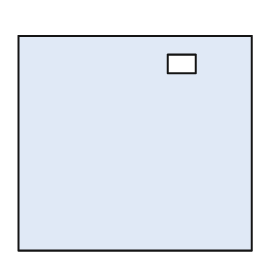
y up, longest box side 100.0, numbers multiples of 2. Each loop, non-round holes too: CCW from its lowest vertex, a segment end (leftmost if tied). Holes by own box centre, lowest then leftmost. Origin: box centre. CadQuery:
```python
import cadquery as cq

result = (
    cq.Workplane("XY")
    .moveTo(-50.0, -46.0)
    .lineTo(50.0, -46.0)
    .lineTo(50.0, 46.0)
    .lineTo(-50.0, 46.0)
    .close()
    .moveTo(14.0, 30.0)
    .lineTo(26.0, 30.0)
    .lineTo(26.0, 38.0)
    .lineTo(14.0, 38.0)
    .close()
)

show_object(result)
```